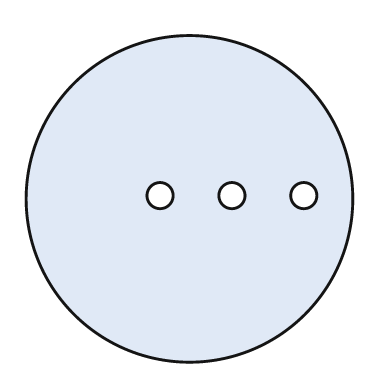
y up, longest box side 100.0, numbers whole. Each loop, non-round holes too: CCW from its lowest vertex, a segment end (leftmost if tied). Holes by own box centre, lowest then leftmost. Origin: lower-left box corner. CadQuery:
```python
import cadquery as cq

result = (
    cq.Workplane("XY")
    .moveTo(50.0, 50.0)
    .circle(50.0)
    .moveTo(41.0, 51.0)
    .circle(4.0)
    .moveTo(63.0, 51.0)
    .circle(4.0)
    .moveTo(85.0, 51.0)
    .circle(4.0)
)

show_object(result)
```